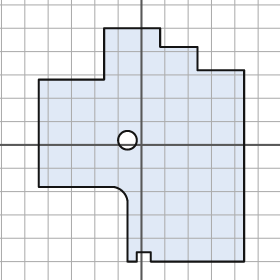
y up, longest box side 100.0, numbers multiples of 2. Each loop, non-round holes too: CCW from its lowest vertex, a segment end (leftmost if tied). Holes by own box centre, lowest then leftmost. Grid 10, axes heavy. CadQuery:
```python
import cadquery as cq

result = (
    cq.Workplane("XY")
    .moveTo(-6.0, -50.0)
    .lineTo(-2.0, -50.0)
    .lineTo(-2.0, -46.0)
    .lineTo(4.0, -46.0)
    .lineTo(4.0, -50.0)
    .lineTo(44.0, -50.0)
    .lineTo(44.0, 32.0)
    .lineTo(24.0, 32.0)
    .lineTo(24.0, 42.0)
    .lineTo(8.0, 42.0)
    .lineTo(8.0, 50.0)
    .lineTo(-16.0, 50.0)
    .lineTo(-16.0, 28.0)
    .lineTo(-44.0, 28.0)
    .lineTo(-44.0, -18.0)
    .lineTo(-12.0, -18.0)
    .threePointArc((-8.0, -20.0), (-6.0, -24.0))
    .close()
    .moveTo(-6.0, 2.0)
    .circle(4.0)
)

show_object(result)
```